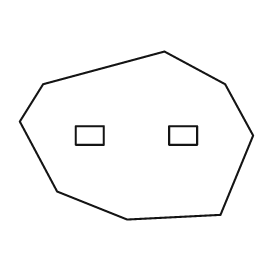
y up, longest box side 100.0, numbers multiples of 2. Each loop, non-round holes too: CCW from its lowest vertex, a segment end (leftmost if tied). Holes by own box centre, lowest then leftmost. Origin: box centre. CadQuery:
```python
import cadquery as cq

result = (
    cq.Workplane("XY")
    .moveTo(-4.0, -36.0)
    .lineTo(36.0, -34.0)
    .lineTo(50.0, 0.0)
    .lineTo(38.0, 22.0)
    .lineTo(12.0, 36.0)
    .lineTo(-40.0, 22.0)
    .lineTo(-50.0, 6.0)
    .lineTo(-34.0, -24.0)
    .close()
    .moveTo(-26.0, -4.0)
    .lineTo(-14.0, -4.0)
    .lineTo(-14.0, 4.0)
    .lineTo(-26.0, 4.0)
    .close()
    .moveTo(14.0, -4.0)
    .lineTo(26.0, -4.0)
    .lineTo(26.0, 4.0)
    .lineTo(14.0, 4.0)
    .close()
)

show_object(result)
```